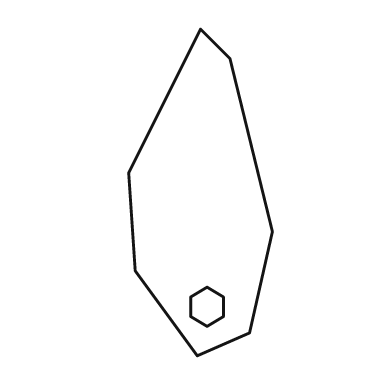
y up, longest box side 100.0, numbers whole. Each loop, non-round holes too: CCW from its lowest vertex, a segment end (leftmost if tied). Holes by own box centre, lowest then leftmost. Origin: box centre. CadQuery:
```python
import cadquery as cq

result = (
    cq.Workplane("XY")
    .moveTo(-1.0, -50.0)
    .lineTo(15.0, -43.0)
    .lineTo(22.0, -12.0)
    .lineTo(9.0, 41.0)
    .lineTo(0.0, 50.0)
    .lineTo(-22.0, 6.0)
    .lineTo(-20.0, -24.0)
    .close()
    .moveTo(2.0, -41.0)
    .lineTo(7.0, -38.0)
    .lineTo(7.0, -32.0)
    .lineTo(2.0, -29.0)
    .lineTo(-3.0, -32.0)
    .lineTo(-3.0, -38.0)
    .close()
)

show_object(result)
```